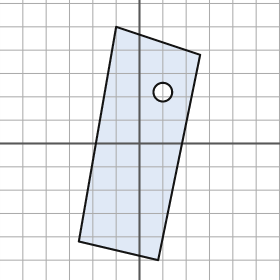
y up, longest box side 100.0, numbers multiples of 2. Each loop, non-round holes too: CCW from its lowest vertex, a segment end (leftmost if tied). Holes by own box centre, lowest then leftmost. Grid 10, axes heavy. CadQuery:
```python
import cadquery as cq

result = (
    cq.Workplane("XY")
    .moveTo(8.0, -50.0)
    .lineTo(26.0, 38.0)
    .lineTo(-10.0, 50.0)
    .lineTo(-26.0, -42.0)
    .close()
    .moveTo(10.0, 22.0)
    .circle(4.0)
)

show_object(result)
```